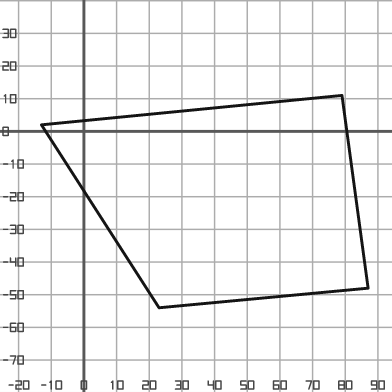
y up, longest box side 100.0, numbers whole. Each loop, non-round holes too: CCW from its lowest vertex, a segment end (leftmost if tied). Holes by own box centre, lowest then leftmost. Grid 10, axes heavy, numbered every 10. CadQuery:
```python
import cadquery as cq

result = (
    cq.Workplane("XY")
    .moveTo(23.0, -54.0)
    .lineTo(87.0, -48.0)
    .lineTo(79.0, 11.0)
    .lineTo(-13.0, 2.0)
    .close()
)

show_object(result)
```